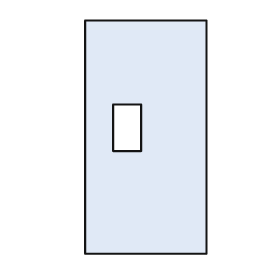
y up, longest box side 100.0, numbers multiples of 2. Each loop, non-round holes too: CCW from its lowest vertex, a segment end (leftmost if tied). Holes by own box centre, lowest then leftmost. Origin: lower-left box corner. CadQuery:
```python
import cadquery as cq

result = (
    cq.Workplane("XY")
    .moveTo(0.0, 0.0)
    .lineTo(52.0, 0.0)
    .lineTo(52.0, 100.0)
    .lineTo(0.0, 100.0)
    .close()
    .moveTo(12.0, 44.0)
    .lineTo(24.0, 44.0)
    .lineTo(24.0, 64.0)
    .lineTo(12.0, 64.0)
    .close()
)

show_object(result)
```